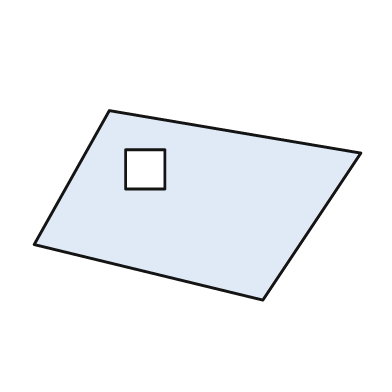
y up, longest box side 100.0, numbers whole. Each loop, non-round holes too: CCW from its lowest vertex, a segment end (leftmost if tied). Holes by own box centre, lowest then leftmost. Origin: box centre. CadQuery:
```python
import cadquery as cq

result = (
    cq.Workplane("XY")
    .moveTo(20.0, -29.0)
    .lineTo(50.0, 16.0)
    .lineTo(-27.0, 29.0)
    .lineTo(-50.0, -12.0)
    .close()
    .moveTo(-22.0, 5.0)
    .lineTo(-10.0, 5.0)
    .lineTo(-10.0, 17.0)
    .lineTo(-22.0, 17.0)
    .close()
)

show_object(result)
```